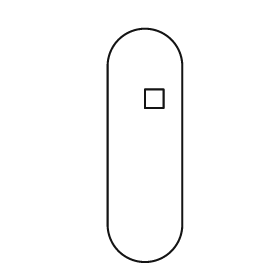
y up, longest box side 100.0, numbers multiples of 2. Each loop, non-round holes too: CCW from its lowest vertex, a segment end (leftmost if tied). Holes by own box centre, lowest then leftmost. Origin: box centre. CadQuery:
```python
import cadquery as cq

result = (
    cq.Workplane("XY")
    .moveTo(-16.0, -34.0)
    .threePointArc((0.0, -50.0), (16.0, -34.0))
    .lineTo(16.0, 34.0)
    .threePointArc((0.0, 50.0), (-16.0, 34.0))
    .close()
    .moveTo(0.0, 16.0)
    .lineTo(8.0, 16.0)
    .lineTo(8.0, 24.0)
    .lineTo(0.0, 24.0)
    .close()
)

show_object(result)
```